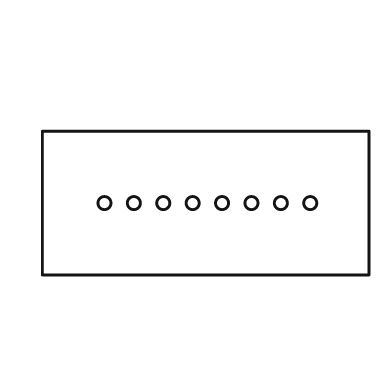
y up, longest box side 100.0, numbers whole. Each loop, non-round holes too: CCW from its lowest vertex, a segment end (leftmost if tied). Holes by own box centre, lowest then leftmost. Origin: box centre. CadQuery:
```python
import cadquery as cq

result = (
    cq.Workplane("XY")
    .moveTo(-50.0, -22.0)
    .lineTo(50.0, -22.0)
    .lineTo(50.0, 22.0)
    .lineTo(-50.0, 22.0)
    .close()
    .moveTo(-31.0, 0.0)
    .circle(2.0)
    .moveTo(-22.0, 0.0)
    .circle(2.0)
    .moveTo(-13.0, 0.0)
    .circle(2.0)
    .moveTo(-4.0, 0.0)
    .circle(2.0)
    .moveTo(5.0, 0.0)
    .circle(2.0)
    .moveTo(14.0, 0.0)
    .circle(2.0)
    .moveTo(23.0, 0.0)
    .circle(2.0)
    .moveTo(32.0, 0.0)
    .circle(2.0)
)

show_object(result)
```